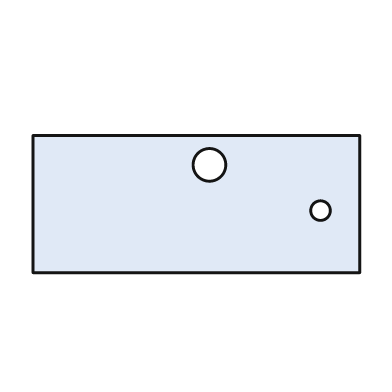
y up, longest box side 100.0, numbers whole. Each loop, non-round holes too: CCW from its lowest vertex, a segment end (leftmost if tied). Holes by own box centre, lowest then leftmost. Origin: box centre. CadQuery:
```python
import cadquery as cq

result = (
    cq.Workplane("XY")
    .moveTo(-50.0, -21.0)
    .lineTo(50.0, -21.0)
    .lineTo(50.0, 21.0)
    .lineTo(-50.0, 21.0)
    .close()
    .moveTo(38.0, -2.0)
    .circle(3.0)
    .moveTo(4.0, 12.0)
    .circle(5.0)
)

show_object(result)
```